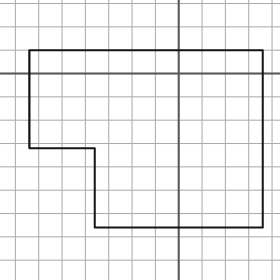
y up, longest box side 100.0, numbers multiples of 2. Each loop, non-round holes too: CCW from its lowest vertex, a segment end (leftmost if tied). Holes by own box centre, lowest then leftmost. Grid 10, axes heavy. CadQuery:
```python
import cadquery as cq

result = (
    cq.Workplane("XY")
    .moveTo(-36.0, -66.0)
    .lineTo(36.0, -66.0)
    .lineTo(36.0, 10.0)
    .lineTo(-64.0, 10.0)
    .lineTo(-64.0, -32.0)
    .lineTo(-36.0, -32.0)
    .close()
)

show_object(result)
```